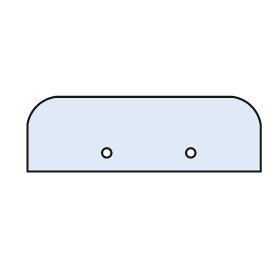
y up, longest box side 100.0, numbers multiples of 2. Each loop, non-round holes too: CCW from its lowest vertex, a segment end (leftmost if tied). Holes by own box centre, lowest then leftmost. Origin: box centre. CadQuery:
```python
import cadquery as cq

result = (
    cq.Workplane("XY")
    .moveTo(-50.0, -16.0)
    .lineTo(50.0, -16.0)
    .lineTo(50.0, 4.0)
    .threePointArc((46.0, 12.0), (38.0, 16.0))
    .lineTo(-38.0, 16.0)
    .threePointArc((-46.0, 12.0), (-50.0, 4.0))
    .close()
    .moveTo(-16.0, -8.0)
    .circle(2.0)
    .moveTo(20.0, -8.0)
    .circle(2.0)
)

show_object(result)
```